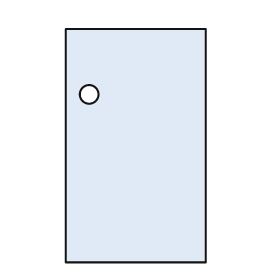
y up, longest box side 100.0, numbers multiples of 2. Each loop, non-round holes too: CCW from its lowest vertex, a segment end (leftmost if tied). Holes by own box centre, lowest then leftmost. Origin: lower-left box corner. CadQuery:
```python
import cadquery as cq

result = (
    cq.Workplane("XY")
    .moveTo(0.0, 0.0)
    .lineTo(60.0, 0.0)
    .lineTo(60.0, 100.0)
    .lineTo(0.0, 100.0)
    .close()
    .moveTo(10.0, 72.0)
    .circle(4.0)
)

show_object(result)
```